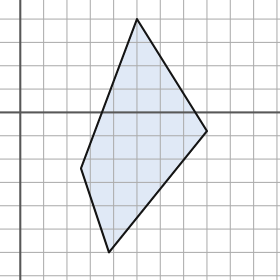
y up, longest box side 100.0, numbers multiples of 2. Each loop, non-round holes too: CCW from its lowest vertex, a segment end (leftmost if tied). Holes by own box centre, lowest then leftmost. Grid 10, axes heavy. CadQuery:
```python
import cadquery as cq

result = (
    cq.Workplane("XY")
    .moveTo(38.0, -60.0)
    .lineTo(80.0, -8.0)
    .lineTo(50.0, 40.0)
    .lineTo(26.0, -24.0)
    .close()
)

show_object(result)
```